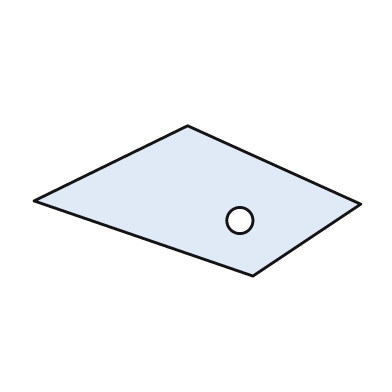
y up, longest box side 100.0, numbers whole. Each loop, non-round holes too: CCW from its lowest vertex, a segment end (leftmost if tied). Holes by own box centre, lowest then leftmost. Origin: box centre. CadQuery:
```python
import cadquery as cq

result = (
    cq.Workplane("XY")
    .moveTo(17.0, -23.0)
    .lineTo(50.0, -1.0)
    .lineTo(-3.0, 23.0)
    .lineTo(-50.0, 0.0)
    .close()
    .moveTo(13.0, -6.0)
    .circle(4.0)
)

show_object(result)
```